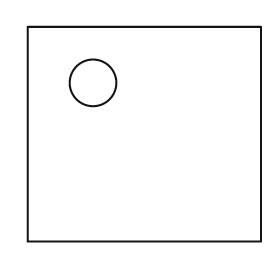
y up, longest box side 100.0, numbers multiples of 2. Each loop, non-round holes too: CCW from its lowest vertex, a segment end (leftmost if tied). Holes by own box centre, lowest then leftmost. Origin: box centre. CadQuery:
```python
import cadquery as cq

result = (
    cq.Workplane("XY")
    .moveTo(-50.0, -46.0)
    .lineTo(50.0, -46.0)
    .lineTo(50.0, 46.0)
    .lineTo(-50.0, 46.0)
    .close()
    .moveTo(-22.0, 22.0)
    .circle(10.0)
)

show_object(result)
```